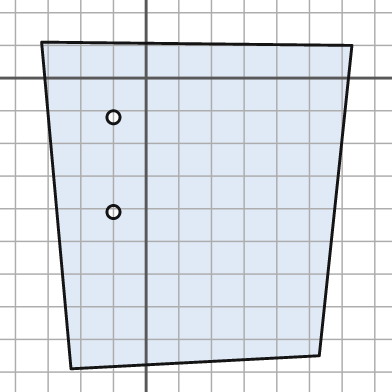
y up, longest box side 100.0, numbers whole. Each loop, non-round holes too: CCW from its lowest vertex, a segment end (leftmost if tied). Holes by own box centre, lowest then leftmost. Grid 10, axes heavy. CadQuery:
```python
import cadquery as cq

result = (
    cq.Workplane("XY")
    .moveTo(-23.0, -89.0)
    .lineTo(53.0, -85.0)
    .lineTo(63.0, 10.0)
    .lineTo(-32.0, 11.0)
    .close()
    .moveTo(-10.0, -41.0)
    .circle(2.0)
    .moveTo(-10.0, -12.0)
    .circle(2.0)
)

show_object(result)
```